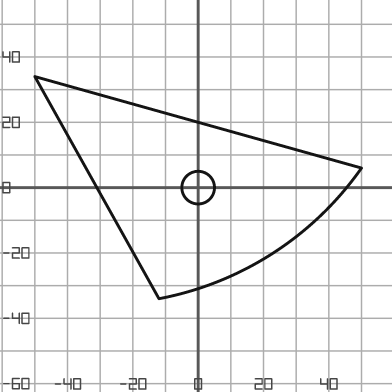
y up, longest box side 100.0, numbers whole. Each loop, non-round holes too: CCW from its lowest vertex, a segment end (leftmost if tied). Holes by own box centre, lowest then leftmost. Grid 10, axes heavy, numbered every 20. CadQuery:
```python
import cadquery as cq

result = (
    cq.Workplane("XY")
    .moveTo(-12.0, -34.0)
    .threePointArc((23.0, -20.0), (50.0, 6.0))
    .lineTo(-50.0, 34.0)
    .close()
    .moveTo(0.0, 0.0)
    .circle(5.0)
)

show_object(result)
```